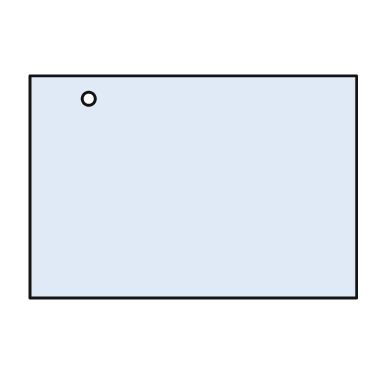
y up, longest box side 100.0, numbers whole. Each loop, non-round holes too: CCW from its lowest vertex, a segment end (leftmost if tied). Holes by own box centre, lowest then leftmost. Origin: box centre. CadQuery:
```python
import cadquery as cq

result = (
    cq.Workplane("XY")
    .moveTo(-50.0, -34.0)
    .lineTo(50.0, -34.0)
    .lineTo(50.0, 34.0)
    .lineTo(-50.0, 34.0)
    .close()
    .moveTo(-32.0, 27.0)
    .circle(2.0)
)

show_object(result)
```